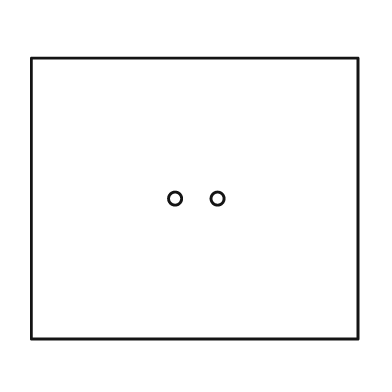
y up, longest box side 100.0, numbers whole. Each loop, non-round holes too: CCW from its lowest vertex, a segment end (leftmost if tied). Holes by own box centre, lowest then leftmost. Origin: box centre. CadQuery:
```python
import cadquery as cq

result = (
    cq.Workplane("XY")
    .moveTo(-50.0, -43.0)
    .lineTo(50.0, -43.0)
    .lineTo(50.0, 43.0)
    .lineTo(-50.0, 43.0)
    .close()
    .moveTo(-6.0, 0.0)
    .circle(2.0)
    .moveTo(7.0, 0.0)
    .circle(2.0)
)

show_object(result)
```